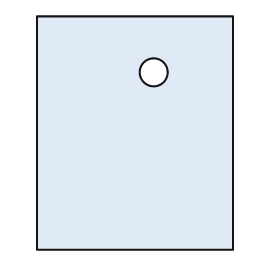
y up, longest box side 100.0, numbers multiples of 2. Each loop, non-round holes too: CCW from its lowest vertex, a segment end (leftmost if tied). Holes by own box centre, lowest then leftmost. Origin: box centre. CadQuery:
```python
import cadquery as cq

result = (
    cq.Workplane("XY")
    .moveTo(-42.0, -50.0)
    .lineTo(42.0, -50.0)
    .lineTo(42.0, 50.0)
    .lineTo(-42.0, 50.0)
    .close()
    .moveTo(8.0, 26.0)
    .circle(6.0)
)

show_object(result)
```